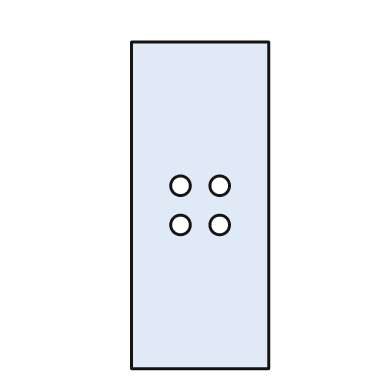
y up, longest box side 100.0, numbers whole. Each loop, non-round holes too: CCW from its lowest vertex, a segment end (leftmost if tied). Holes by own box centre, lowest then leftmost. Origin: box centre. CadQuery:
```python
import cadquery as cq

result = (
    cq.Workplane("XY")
    .moveTo(-21.0, -50.0)
    .lineTo(21.0, -50.0)
    .lineTo(21.0, 50.0)
    .lineTo(-21.0, 50.0)
    .close()
    .moveTo(-6.0, -6.0)
    .circle(3.0)
    .moveTo(6.0, -6.0)
    .circle(3.0)
    .moveTo(-6.0, 6.0)
    .circle(3.0)
    .moveTo(6.0, 6.0)
    .circle(3.0)
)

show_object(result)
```